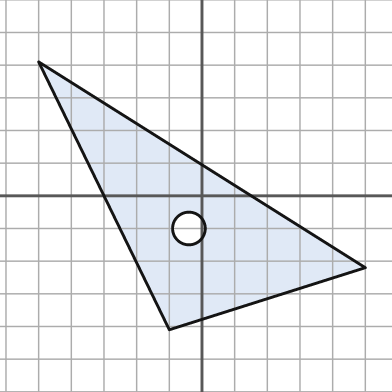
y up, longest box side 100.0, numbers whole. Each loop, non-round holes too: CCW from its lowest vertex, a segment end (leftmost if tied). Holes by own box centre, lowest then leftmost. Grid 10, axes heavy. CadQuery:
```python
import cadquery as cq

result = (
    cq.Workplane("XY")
    .moveTo(-10.0, -41.0)
    .lineTo(50.0, -22.0)
    .lineTo(-50.0, 41.0)
    .close()
    .moveTo(-4.0, -10.0)
    .circle(5.0)
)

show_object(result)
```